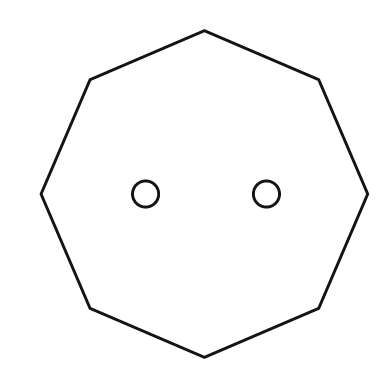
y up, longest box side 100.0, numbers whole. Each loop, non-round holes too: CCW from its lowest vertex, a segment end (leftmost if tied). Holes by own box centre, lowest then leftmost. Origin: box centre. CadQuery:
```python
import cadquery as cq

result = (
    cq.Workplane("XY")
    .moveTo(0.0, -50.0)
    .lineTo(35.0, -35.0)
    .lineTo(50.0, 0.0)
    .lineTo(35.0, 35.0)
    .lineTo(0.0, 50.0)
    .lineTo(-35.0, 35.0)
    .lineTo(-50.0, 0.0)
    .lineTo(-35.0, -35.0)
    .close()
    .moveTo(-18.0, 0.0)
    .circle(4.0)
    .moveTo(19.0, 0.0)
    .circle(4.0)
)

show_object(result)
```